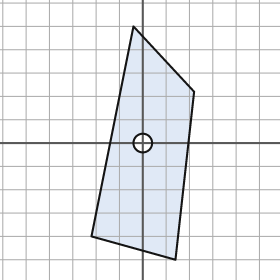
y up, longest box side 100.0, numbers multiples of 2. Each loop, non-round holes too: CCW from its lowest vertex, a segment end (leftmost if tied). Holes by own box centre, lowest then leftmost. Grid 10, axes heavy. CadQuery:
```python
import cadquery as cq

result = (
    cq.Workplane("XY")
    .moveTo(14.0, -50.0)
    .lineTo(22.0, 22.0)
    .lineTo(-4.0, 50.0)
    .lineTo(-22.0, -40.0)
    .close()
    .moveTo(0.0, 0.0)
    .circle(4.0)
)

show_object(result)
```